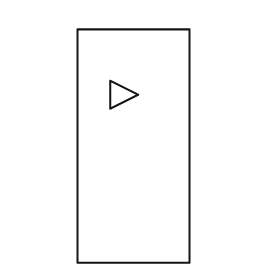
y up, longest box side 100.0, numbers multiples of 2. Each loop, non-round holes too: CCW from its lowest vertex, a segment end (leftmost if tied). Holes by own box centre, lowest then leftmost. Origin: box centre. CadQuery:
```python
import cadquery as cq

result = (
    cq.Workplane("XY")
    .moveTo(-24.0, -50.0)
    .lineTo(24.0, -50.0)
    .lineTo(24.0, 50.0)
    .lineTo(-24.0, 50.0)
    .close()
    .moveTo(-10.0, 16.0)
    .lineTo(2.0, 22.0)
    .lineTo(-10.0, 28.0)
    .close()
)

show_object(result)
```